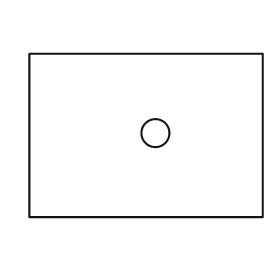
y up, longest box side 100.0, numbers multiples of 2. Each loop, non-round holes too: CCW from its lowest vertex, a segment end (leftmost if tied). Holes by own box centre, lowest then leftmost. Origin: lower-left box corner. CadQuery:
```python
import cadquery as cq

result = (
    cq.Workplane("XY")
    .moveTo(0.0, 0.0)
    .lineTo(100.0, 0.0)
    .lineTo(100.0, 70.0)
    .lineTo(0.0, 70.0)
    .close()
    .moveTo(54.0, 36.0)
    .circle(6.0)
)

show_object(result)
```